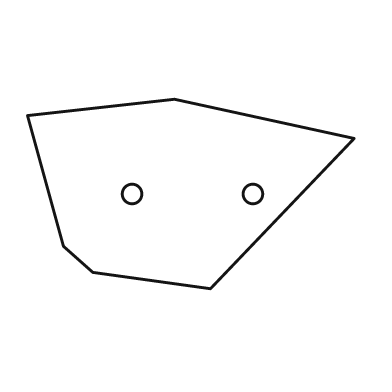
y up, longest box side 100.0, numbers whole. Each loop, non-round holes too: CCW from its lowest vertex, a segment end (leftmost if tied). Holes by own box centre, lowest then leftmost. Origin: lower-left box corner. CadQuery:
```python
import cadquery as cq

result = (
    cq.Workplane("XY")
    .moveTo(56.0, 0.0)
    .lineTo(100.0, 46.0)
    .lineTo(45.0, 58.0)
    .lineTo(0.0, 53.0)
    .lineTo(11.0, 13.0)
    .lineTo(20.0, 5.0)
    .close()
    .moveTo(32.0, 29.0)
    .circle(3.0)
    .moveTo(69.0, 29.0)
    .circle(3.0)
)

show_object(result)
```